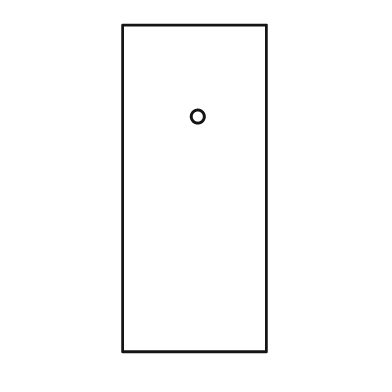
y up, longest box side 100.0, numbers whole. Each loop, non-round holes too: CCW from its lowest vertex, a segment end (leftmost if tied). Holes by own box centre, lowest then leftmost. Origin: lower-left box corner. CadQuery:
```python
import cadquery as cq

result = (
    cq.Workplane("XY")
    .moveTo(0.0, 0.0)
    .lineTo(44.0, 0.0)
    .lineTo(44.0, 100.0)
    .lineTo(0.0, 100.0)
    .close()
    .moveTo(23.0, 72.0)
    .circle(2.0)
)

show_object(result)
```